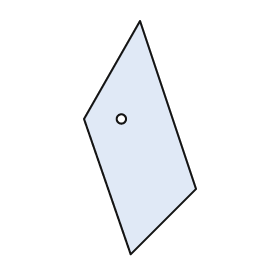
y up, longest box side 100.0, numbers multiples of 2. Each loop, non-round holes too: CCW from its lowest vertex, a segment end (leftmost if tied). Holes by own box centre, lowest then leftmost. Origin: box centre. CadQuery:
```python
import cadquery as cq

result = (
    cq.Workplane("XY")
    .moveTo(-4.0, -50.0)
    .lineTo(24.0, -22.0)
    .lineTo(0.0, 50.0)
    .lineTo(-24.0, 8.0)
    .close()
    .moveTo(-8.0, 8.0)
    .circle(2.0)
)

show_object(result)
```